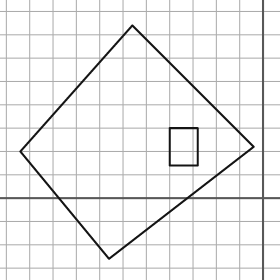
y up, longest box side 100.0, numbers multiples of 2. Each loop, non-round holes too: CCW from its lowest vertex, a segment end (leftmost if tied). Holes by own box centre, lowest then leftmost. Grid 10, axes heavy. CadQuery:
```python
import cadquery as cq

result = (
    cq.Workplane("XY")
    .moveTo(-66.0, -26.0)
    .lineTo(-4.0, 22.0)
    .lineTo(-56.0, 74.0)
    .lineTo(-104.0, 20.0)
    .close()
    .moveTo(-40.0, 14.0)
    .lineTo(-28.0, 14.0)
    .lineTo(-28.0, 30.0)
    .lineTo(-40.0, 30.0)
    .close()
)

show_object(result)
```